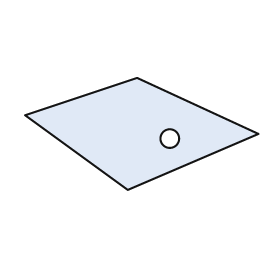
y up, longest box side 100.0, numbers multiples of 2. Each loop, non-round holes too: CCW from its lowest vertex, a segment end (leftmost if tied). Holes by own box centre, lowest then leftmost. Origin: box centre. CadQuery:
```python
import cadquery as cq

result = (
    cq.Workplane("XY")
    .moveTo(-6.0, -24.0)
    .lineTo(50.0, 0.0)
    .lineTo(-2.0, 24.0)
    .lineTo(-50.0, 8.0)
    .close()
    .moveTo(12.0, -2.0)
    .circle(4.0)
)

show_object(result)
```